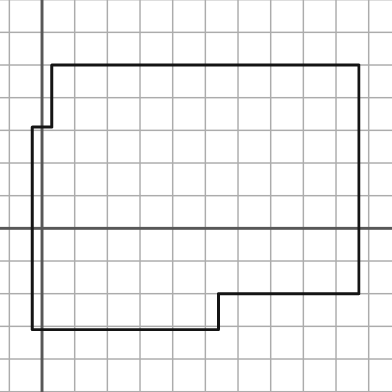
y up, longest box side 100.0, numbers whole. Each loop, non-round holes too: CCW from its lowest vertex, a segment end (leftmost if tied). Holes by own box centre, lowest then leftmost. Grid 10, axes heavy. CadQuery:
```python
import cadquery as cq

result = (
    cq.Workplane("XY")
    .moveTo(-3.0, -31.0)
    .lineTo(54.0, -31.0)
    .lineTo(54.0, -20.0)
    .lineTo(97.0, -20.0)
    .lineTo(97.0, 50.0)
    .lineTo(3.0, 50.0)
    .lineTo(3.0, 31.0)
    .lineTo(-3.0, 31.0)
    .close()
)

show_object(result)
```